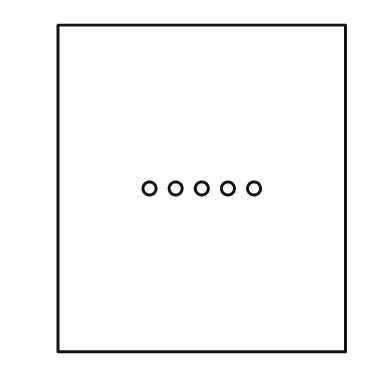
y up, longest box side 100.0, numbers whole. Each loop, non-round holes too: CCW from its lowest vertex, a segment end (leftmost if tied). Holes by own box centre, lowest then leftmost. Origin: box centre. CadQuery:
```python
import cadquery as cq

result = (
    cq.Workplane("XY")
    .moveTo(-44.0, -50.0)
    .lineTo(44.0, -50.0)
    .lineTo(44.0, 50.0)
    .lineTo(-44.0, 50.0)
    .close()
    .moveTo(-16.0, 0.0)
    .circle(2.0)
    .moveTo(-8.0, 0.0)
    .circle(2.0)
    .moveTo(0.0, 0.0)
    .circle(2.0)
    .moveTo(8.0, 0.0)
    .circle(2.0)
    .moveTo(16.0, 0.0)
    .circle(2.0)
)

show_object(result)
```